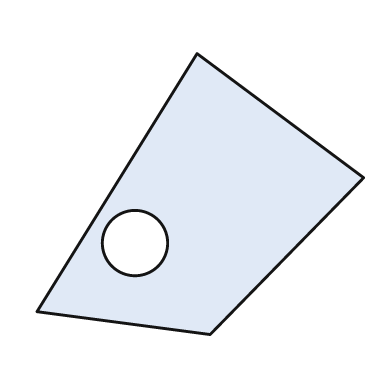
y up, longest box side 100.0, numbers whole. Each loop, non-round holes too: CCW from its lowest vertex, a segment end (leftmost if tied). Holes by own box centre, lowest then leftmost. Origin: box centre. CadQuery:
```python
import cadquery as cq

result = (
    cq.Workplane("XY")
    .moveTo(3.0, -43.0)
    .lineTo(50.0, 5.0)
    .lineTo(-1.0, 43.0)
    .lineTo(-50.0, -36.0)
    .close()
    .moveTo(-20.0, -15.0)
    .circle(10.0)
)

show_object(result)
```